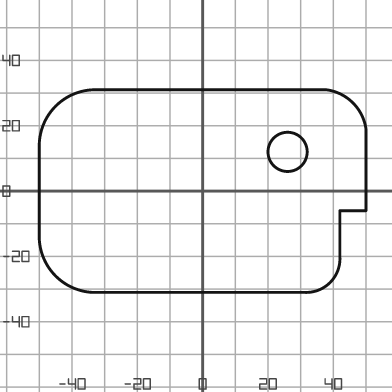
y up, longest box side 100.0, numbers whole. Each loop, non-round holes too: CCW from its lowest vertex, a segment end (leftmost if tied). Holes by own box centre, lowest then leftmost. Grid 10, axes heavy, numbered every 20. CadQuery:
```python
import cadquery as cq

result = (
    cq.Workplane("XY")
    .moveTo(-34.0, -31.0)
    .lineTo(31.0, -31.0)
    .threePointArc((39.0, -28.0), (42.0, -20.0))
    .lineTo(42.0, -6.0)
    .lineTo(50.0, -6.0)
    .lineTo(50.0, 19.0)
    .threePointArc((46.0, 27.0), (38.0, 31.0))
    .lineTo(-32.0, 31.0)
    .threePointArc((-45.0, 26.0), (-50.0, 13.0))
    .lineTo(-50.0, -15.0)
    .threePointArc((-45.0, -26.0), (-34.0, -31.0))
    .close()
    .moveTo(26.0, 12.0)
    .circle(6.0)
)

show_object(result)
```